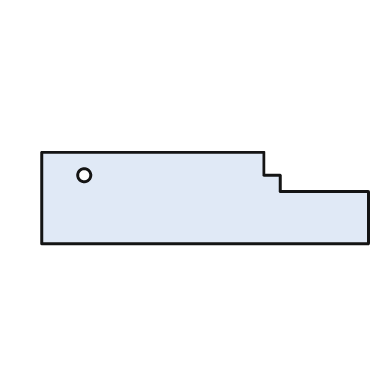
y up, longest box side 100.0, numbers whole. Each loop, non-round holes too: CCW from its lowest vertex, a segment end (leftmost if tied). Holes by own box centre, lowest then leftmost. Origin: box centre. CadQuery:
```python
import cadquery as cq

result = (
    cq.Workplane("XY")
    .moveTo(-50.0, -14.0)
    .lineTo(50.0, -14.0)
    .lineTo(50.0, 2.0)
    .lineTo(23.0, 2.0)
    .lineTo(23.0, 7.0)
    .lineTo(18.0, 7.0)
    .lineTo(18.0, 14.0)
    .lineTo(-50.0, 14.0)
    .close()
    .moveTo(-37.0, 7.0)
    .circle(2.0)
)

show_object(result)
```